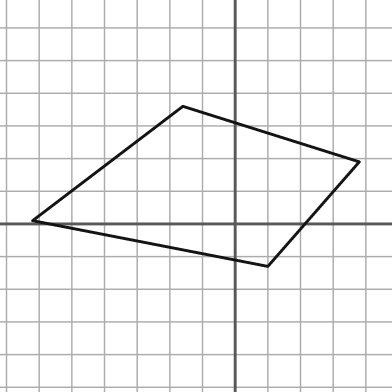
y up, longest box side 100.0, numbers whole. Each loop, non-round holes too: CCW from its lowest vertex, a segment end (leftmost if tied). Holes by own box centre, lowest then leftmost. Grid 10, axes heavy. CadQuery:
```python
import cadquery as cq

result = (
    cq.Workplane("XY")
    .moveTo(10.0, -13.0)
    .lineTo(38.0, 19.0)
    .lineTo(-16.0, 36.0)
    .lineTo(-62.0, 1.0)
    .close()
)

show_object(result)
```